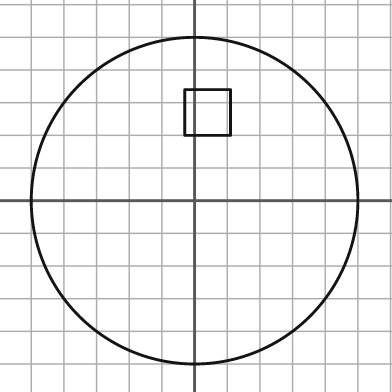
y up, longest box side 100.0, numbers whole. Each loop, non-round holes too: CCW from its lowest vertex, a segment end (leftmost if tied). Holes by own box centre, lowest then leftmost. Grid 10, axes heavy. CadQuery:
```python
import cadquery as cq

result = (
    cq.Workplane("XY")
    .moveTo(0.0, 0.0)
    .circle(50.0)
    .moveTo(-3.0, 20.0)
    .lineTo(11.0, 20.0)
    .lineTo(11.0, 34.0)
    .lineTo(-3.0, 34.0)
    .close()
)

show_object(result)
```